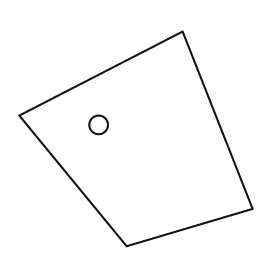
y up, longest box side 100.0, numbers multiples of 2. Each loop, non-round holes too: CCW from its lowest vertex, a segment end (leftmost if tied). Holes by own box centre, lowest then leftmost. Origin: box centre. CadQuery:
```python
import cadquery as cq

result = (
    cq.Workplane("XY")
    .moveTo(-4.0, -46.0)
    .lineTo(50.0, -30.0)
    .lineTo(20.0, 46.0)
    .lineTo(-50.0, 10.0)
    .close()
    .moveTo(-16.0, 6.0)
    .circle(4.0)
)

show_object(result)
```